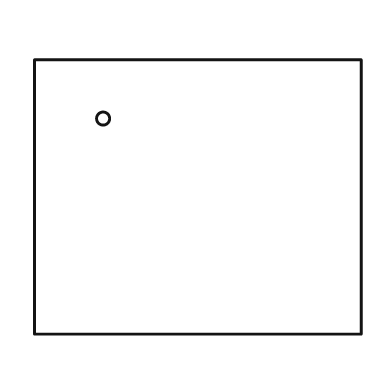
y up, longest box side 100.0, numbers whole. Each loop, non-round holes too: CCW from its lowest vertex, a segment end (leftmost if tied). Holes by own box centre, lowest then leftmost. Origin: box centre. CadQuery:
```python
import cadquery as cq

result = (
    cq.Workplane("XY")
    .moveTo(-50.0, -42.0)
    .lineTo(50.0, -42.0)
    .lineTo(50.0, 42.0)
    .lineTo(-50.0, 42.0)
    .close()
    .moveTo(-29.0, 24.0)
    .circle(2.0)
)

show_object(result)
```